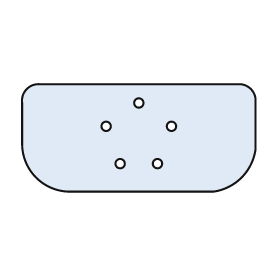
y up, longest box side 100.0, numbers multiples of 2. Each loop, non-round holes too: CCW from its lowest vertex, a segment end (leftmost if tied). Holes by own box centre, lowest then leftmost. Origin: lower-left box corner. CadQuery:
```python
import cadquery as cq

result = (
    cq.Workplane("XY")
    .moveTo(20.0, 0.0)
    .lineTo(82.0, 0.0)
    .threePointArc((94.0, 6.0), (100.0, 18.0))
    .lineTo(100.0, 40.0)
    .threePointArc((98.0, 44.0), (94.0, 46.0))
    .lineTo(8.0, 46.0)
    .threePointArc((2.0, 44.0), (0.0, 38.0))
    .lineTo(0.0, 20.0)
    .threePointArc((6.0, 6.0), (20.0, 0.0))
    .close()
    .moveTo(42.0, 12.0)
    .circle(2.0)
    .moveTo(58.0, 12.0)
    .circle(2.0)
    .moveTo(36.0, 28.0)
    .circle(2.0)
    .moveTo(64.0, 28.0)
    .circle(2.0)
    .moveTo(50.0, 38.0)
    .circle(2.0)
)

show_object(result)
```